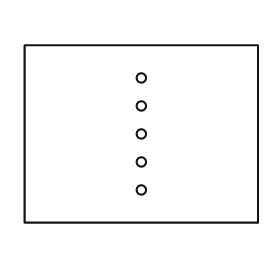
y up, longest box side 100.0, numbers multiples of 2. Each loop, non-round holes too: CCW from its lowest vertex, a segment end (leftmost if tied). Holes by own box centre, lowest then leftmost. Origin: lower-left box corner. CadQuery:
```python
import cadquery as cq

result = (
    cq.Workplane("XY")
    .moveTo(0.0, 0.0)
    .lineTo(100.0, 0.0)
    .lineTo(100.0, 76.0)
    .lineTo(0.0, 76.0)
    .close()
    .moveTo(50.0, 14.0)
    .circle(2.0)
    .moveTo(50.0, 26.0)
    .circle(2.0)
    .moveTo(50.0, 38.0)
    .circle(2.0)
    .moveTo(50.0, 50.0)
    .circle(2.0)
    .moveTo(50.0, 62.0)
    .circle(2.0)
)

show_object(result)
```